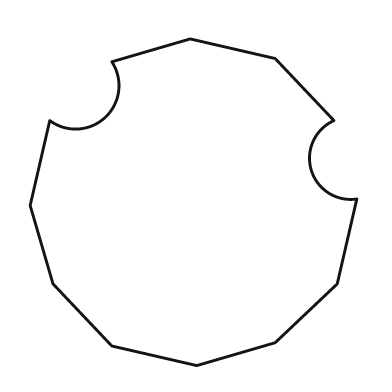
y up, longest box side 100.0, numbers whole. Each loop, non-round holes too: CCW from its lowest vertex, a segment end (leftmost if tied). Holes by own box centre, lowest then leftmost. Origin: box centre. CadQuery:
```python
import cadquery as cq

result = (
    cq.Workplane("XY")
    .moveTo(1.0, -50.0)
    .lineTo(25.0, -43.0)
    .lineTo(44.0, -25.0)
    .lineTo(50.0, 1.0)
    .threePointArc((36.0, 10.0), (43.0, 25.0))
    .lineTo(25.0, 44.0)
    .lineTo(-1.0, 50.0)
    .lineTo(-25.0, 43.0)
    .threePointArc((-27.0, 26.0), (-44.0, 25.0))
    .lineTo(-50.0, -1.0)
    .lineTo(-43.0, -25.0)
    .lineTo(-25.0, -44.0)
    .close()
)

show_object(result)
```